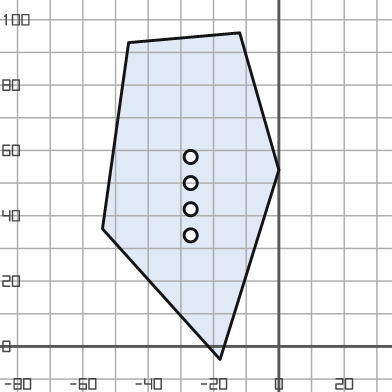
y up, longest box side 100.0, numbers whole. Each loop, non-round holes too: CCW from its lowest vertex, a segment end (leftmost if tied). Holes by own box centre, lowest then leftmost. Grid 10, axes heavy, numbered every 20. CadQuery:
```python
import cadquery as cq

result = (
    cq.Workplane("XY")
    .moveTo(-18.0, -4.0)
    .lineTo(0.0, 54.0)
    .lineTo(-12.0, 96.0)
    .lineTo(-46.0, 93.0)
    .lineTo(-54.0, 36.0)
    .close()
    .moveTo(-27.0, 34.0)
    .circle(2.0)
    .moveTo(-27.0, 42.0)
    .circle(2.0)
    .moveTo(-27.0, 50.0)
    .circle(2.0)
    .moveTo(-27.0, 58.0)
    .circle(2.0)
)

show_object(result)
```